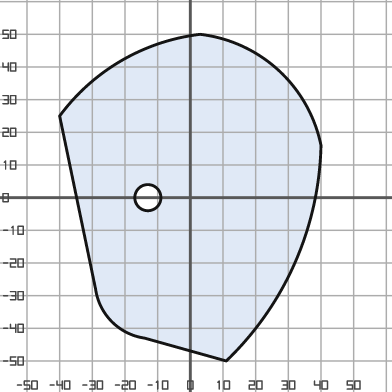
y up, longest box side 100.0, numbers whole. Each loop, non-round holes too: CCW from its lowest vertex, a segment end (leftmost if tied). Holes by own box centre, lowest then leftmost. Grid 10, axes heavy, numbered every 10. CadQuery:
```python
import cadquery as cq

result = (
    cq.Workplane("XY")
    .moveTo(11.0, -50.0)
    .threePointArc((32.0, -20.0), (40.0, 16.0))
    .threePointArc((27.0, 39.0), (3.0, 50.0))
    .threePointArc((-21.0, 42.0), (-40.0, 25.0))
    .lineTo(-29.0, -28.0)
    .threePointArc((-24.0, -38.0), (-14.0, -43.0))
    .close()
    .moveTo(-13.0, 0.0)
    .circle(4.0)
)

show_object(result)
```